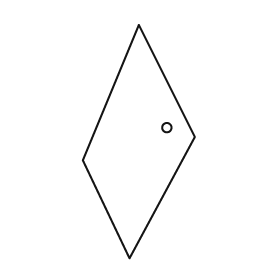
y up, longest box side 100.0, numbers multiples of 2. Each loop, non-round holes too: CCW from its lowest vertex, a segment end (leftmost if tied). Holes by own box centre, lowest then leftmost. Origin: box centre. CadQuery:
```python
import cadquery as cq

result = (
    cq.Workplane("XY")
    .moveTo(-4.0, -50.0)
    .lineTo(24.0, 2.0)
    .lineTo(0.0, 50.0)
    .lineTo(-24.0, -8.0)
    .close()
    .moveTo(12.0, 6.0)
    .circle(2.0)
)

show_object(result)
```